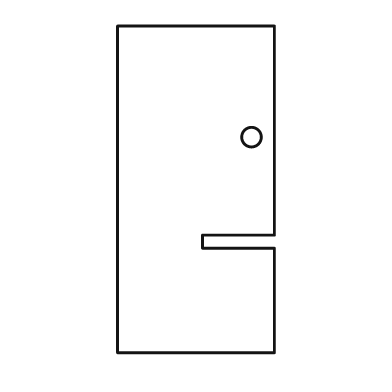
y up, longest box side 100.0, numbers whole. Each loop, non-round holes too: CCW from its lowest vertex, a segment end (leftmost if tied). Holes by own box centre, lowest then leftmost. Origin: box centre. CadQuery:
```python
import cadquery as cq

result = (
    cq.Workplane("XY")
    .moveTo(-24.0, -50.0)
    .lineTo(24.0, -50.0)
    .lineTo(24.0, -18.0)
    .lineTo(2.0, -18.0)
    .lineTo(2.0, -14.0)
    .lineTo(24.0, -14.0)
    .lineTo(24.0, 50.0)
    .lineTo(-24.0, 50.0)
    .close()
    .moveTo(17.0, 16.0)
    .circle(3.0)
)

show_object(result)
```